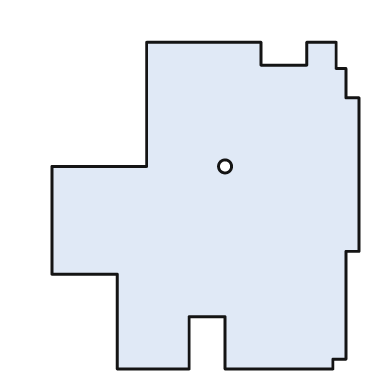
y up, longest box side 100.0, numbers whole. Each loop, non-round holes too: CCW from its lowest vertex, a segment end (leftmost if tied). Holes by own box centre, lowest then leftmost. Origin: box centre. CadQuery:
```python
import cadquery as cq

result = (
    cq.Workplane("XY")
    .moveTo(-27.0, -50.0)
    .lineTo(-5.0, -50.0)
    .lineTo(-5.0, -34.0)
    .lineTo(6.0, -34.0)
    .lineTo(6.0, -50.0)
    .lineTo(39.0, -50.0)
    .lineTo(39.0, -47.0)
    .lineTo(43.0, -47.0)
    .lineTo(43.0, -14.0)
    .lineTo(47.0, -14.0)
    .lineTo(47.0, 33.0)
    .lineTo(43.0, 33.0)
    .lineTo(43.0, 42.0)
    .lineTo(40.0, 42.0)
    .lineTo(40.0, 50.0)
    .lineTo(31.0, 50.0)
    .lineTo(31.0, 43.0)
    .lineTo(17.0, 43.0)
    .lineTo(17.0, 50.0)
    .lineTo(-18.0, 50.0)
    .lineTo(-18.0, 12.0)
    .lineTo(-47.0, 12.0)
    .lineTo(-47.0, -21.0)
    .lineTo(-27.0, -21.0)
    .close()
    .moveTo(6.0, 12.0)
    .circle(2.0)
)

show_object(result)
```